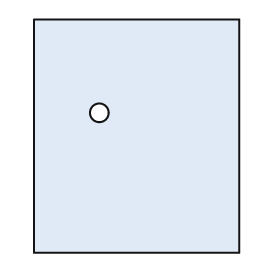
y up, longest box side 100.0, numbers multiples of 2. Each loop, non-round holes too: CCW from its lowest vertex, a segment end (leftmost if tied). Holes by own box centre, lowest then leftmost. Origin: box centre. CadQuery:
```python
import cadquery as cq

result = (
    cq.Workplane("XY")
    .moveTo(-44.0, -50.0)
    .lineTo(44.0, -50.0)
    .lineTo(44.0, 50.0)
    .lineTo(-44.0, 50.0)
    .close()
    .moveTo(-16.0, 10.0)
    .circle(4.0)
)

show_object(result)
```